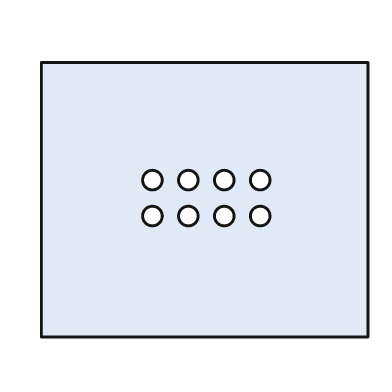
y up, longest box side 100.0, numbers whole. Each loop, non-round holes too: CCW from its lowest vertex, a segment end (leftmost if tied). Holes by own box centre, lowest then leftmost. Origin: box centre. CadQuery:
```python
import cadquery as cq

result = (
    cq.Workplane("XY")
    .moveTo(-50.0, -42.0)
    .lineTo(50.0, -42.0)
    .lineTo(50.0, 42.0)
    .lineTo(-50.0, 42.0)
    .close()
    .moveTo(-16.0, -5.0)
    .circle(3.0)
    .moveTo(-5.0, -5.0)
    .circle(3.0)
    .moveTo(6.0, -5.0)
    .circle(3.0)
    .moveTo(17.0, -5.0)
    .circle(3.0)
    .moveTo(-16.0, 6.0)
    .circle(3.0)
    .moveTo(-5.0, 6.0)
    .circle(3.0)
    .moveTo(6.0, 6.0)
    .circle(3.0)
    .moveTo(17.0, 6.0)
    .circle(3.0)
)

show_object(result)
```